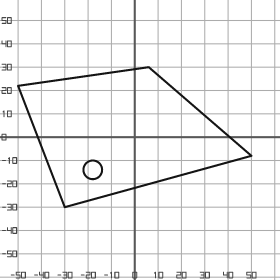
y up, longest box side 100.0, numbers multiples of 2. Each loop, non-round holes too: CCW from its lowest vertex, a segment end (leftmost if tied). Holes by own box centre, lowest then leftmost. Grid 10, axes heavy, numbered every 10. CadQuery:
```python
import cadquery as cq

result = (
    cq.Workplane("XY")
    .moveTo(-30.0, -30.0)
    .lineTo(50.0, -8.0)
    .lineTo(6.0, 30.0)
    .lineTo(-50.0, 22.0)
    .close()
    .moveTo(-18.0, -14.0)
    .circle(4.0)
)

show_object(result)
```